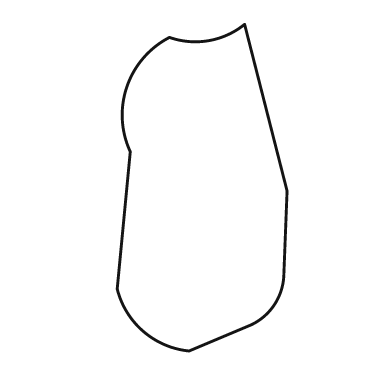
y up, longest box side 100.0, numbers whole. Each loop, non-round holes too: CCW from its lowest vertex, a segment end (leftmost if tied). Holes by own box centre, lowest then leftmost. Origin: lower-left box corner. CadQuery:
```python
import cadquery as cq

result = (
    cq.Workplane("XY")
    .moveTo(22.0, 0.0)
    .lineTo(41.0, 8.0)
    .threePointArc((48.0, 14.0), (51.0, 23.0))
    .lineTo(52.0, 49.0)
    .lineTo(39.0, 100.0)
    .threePointArc((28.0, 95.0), (16.0, 96.0))
    .threePointArc((3.0, 81.0), (4.0, 61.0))
    .lineTo(0.0, 19.0)
    .threePointArc((8.0, 6.0), (22.0, 0.0))
    .close()
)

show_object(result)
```